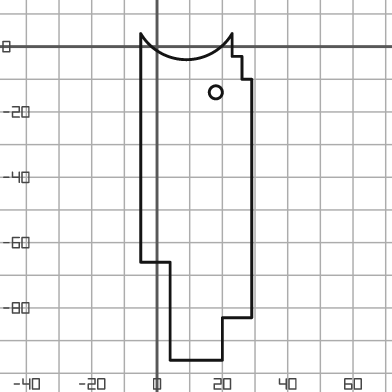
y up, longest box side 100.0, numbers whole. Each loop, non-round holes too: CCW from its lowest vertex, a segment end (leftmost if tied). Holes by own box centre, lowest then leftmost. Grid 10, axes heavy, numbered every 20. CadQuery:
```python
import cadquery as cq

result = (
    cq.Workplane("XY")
    .moveTo(4.0, -96.0)
    .lineTo(20.0, -96.0)
    .lineTo(20.0, -83.0)
    .lineTo(29.0, -83.0)
    .lineTo(29.0, -10.0)
    .lineTo(26.0, -10.0)
    .lineTo(26.0, -3.0)
    .lineTo(23.0, -3.0)
    .lineTo(23.0, 4.0)
    .threePointArc((9.0, -4.0), (-5.0, 4.0))
    .lineTo(-5.0, -66.0)
    .lineTo(4.0, -66.0)
    .close()
    .moveTo(18.0, -14.0)
    .circle(2.0)
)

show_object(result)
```